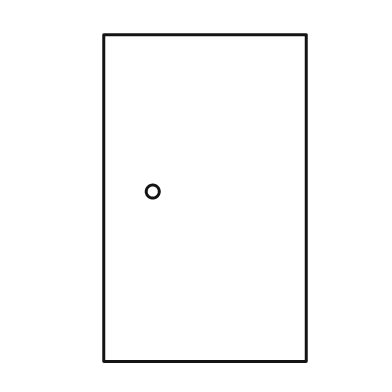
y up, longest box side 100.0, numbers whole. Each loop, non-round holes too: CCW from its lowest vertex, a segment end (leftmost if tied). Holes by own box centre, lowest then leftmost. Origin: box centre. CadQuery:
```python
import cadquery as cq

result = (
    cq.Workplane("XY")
    .moveTo(-31.0, -50.0)
    .lineTo(31.0, -50.0)
    .lineTo(31.0, 50.0)
    .lineTo(-31.0, 50.0)
    .close()
    .moveTo(-16.0, 2.0)
    .circle(2.0)
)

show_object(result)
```